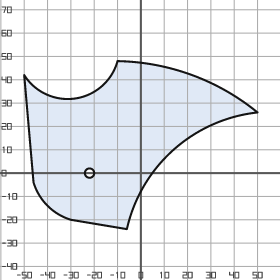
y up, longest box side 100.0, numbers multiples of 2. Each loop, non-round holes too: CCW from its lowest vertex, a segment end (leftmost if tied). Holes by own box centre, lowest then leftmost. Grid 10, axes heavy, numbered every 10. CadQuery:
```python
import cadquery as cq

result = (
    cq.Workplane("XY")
    .moveTo(-6.0, -24.0)
    .threePointArc((14.0, 10.0), (50.0, 26.0))
    .threePointArc((22.0, 42.0), (-10.0, 48.0))
    .threePointArc((-28.0, 32.0), (-50.0, 42.0))
    .lineTo(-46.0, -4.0)
    .threePointArc((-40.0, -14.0), (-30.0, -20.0))
    .close()
    .moveTo(-22.0, 0.0)
    .circle(2.0)
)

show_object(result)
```